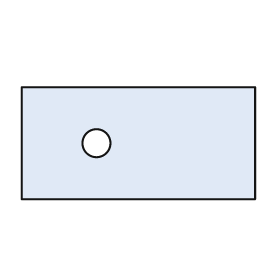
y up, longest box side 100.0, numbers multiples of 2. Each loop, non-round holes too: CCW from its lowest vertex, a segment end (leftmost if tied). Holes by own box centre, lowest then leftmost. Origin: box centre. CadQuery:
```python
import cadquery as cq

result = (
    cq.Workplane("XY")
    .moveTo(-50.0, -24.0)
    .lineTo(50.0, -24.0)
    .lineTo(50.0, 24.0)
    .lineTo(-50.0, 24.0)
    .close()
    .moveTo(-18.0, 0.0)
    .circle(6.0)
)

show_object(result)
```